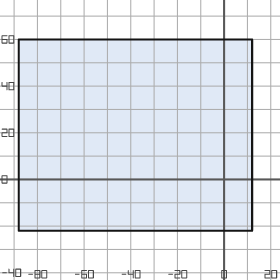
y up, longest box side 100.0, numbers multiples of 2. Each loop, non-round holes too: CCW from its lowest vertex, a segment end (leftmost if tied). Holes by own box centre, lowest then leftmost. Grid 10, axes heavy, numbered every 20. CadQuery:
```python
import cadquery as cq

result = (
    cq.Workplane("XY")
    .moveTo(-88.0, -22.0)
    .lineTo(12.0, -22.0)
    .lineTo(12.0, 60.0)
    .lineTo(-88.0, 60.0)
    .close()
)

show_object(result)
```